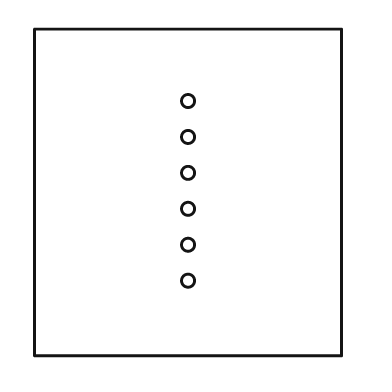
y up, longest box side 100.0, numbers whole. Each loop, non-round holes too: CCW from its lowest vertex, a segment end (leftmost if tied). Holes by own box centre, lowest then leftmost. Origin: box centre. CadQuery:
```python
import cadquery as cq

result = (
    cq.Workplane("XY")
    .moveTo(-47.0, -50.0)
    .lineTo(47.0, -50.0)
    .lineTo(47.0, 50.0)
    .lineTo(-47.0, 50.0)
    .close()
    .moveTo(0.0, -27.0)
    .circle(2.0)
    .moveTo(0.0, -16.0)
    .circle(2.0)
    .moveTo(0.0, -5.0)
    .circle(2.0)
    .moveTo(0.0, 6.0)
    .circle(2.0)
    .moveTo(0.0, 17.0)
    .circle(2.0)
    .moveTo(0.0, 28.0)
    .circle(2.0)
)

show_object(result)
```